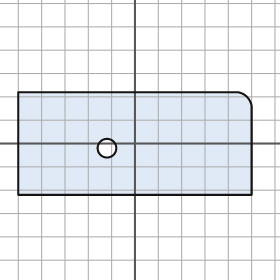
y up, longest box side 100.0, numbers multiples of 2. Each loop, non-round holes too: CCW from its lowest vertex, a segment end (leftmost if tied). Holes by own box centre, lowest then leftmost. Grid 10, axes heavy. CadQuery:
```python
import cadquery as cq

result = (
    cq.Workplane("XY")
    .moveTo(-50.0, -22.0)
    .lineTo(50.0, -22.0)
    .lineTo(50.0, 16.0)
    .threePointArc((48.0, 20.0), (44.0, 22.0))
    .lineTo(-50.0, 22.0)
    .close()
    .moveTo(-12.0, -2.0)
    .circle(4.0)
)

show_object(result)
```